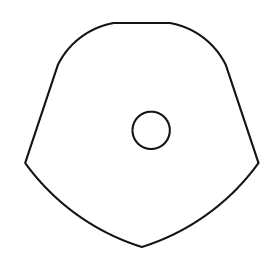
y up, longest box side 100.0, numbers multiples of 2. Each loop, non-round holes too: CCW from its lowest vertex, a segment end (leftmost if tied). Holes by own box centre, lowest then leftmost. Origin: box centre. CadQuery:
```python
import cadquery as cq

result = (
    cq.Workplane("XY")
    .moveTo(0.0, -48.0)
    .threePointArc((28.0, -34.0), (50.0, -12.0))
    .lineTo(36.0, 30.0)
    .threePointArc((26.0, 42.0), (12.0, 48.0))
    .lineTo(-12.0, 48.0)
    .threePointArc((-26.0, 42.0), (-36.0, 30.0))
    .lineTo(-50.0, -12.0)
    .threePointArc((-28.0, -34.0), (0.0, -48.0))
    .close()
    .moveTo(4.0, 2.0)
    .circle(8.0)
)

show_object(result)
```